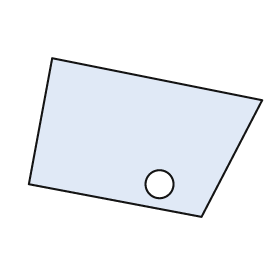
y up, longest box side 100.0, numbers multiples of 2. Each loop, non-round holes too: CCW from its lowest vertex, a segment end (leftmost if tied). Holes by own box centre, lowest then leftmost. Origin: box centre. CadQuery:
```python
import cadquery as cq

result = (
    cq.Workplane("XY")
    .moveTo(24.0, -34.0)
    .lineTo(50.0, 16.0)
    .lineTo(-40.0, 34.0)
    .lineTo(-50.0, -20.0)
    .close()
    .moveTo(6.0, -20.0)
    .circle(6.0)
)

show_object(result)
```